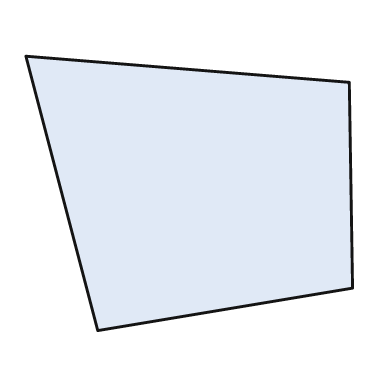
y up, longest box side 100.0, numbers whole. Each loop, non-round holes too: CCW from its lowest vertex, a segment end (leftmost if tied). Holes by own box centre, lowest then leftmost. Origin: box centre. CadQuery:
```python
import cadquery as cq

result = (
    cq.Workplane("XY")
    .moveTo(-28.0, -42.0)
    .lineTo(50.0, -29.0)
    .lineTo(49.0, 34.0)
    .lineTo(-50.0, 42.0)
    .close()
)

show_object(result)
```